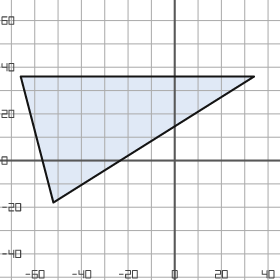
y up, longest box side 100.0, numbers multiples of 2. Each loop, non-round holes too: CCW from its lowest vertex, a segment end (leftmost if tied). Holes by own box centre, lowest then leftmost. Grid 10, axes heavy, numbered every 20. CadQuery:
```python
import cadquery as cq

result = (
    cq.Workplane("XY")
    .moveTo(-52.0, -18.0)
    .lineTo(34.0, 36.0)
    .lineTo(-66.0, 36.0)
    .close()
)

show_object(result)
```